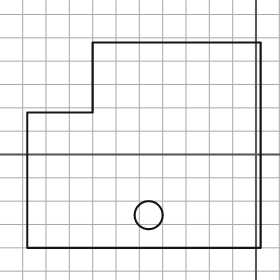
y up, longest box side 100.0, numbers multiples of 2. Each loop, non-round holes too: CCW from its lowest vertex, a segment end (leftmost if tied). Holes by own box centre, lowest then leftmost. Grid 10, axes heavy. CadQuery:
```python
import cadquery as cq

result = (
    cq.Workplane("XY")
    .moveTo(-98.0, -40.0)
    .lineTo(2.0, -40.0)
    .lineTo(2.0, 48.0)
    .lineTo(-70.0, 48.0)
    .lineTo(-70.0, 18.0)
    .lineTo(-98.0, 18.0)
    .close()
    .moveTo(-46.0, -26.0)
    .circle(6.0)
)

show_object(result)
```